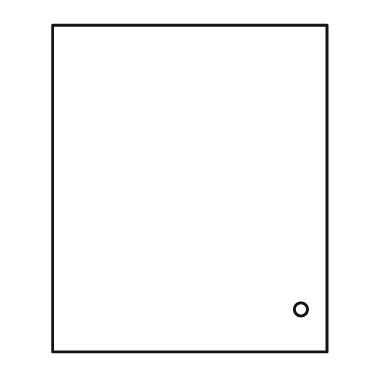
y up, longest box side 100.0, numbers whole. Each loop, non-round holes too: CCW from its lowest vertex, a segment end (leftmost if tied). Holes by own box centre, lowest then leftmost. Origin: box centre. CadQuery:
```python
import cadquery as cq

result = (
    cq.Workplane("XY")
    .moveTo(-42.0, -50.0)
    .lineTo(42.0, -50.0)
    .lineTo(42.0, 50.0)
    .lineTo(-42.0, 50.0)
    .close()
    .moveTo(34.0, -37.0)
    .circle(2.0)
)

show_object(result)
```